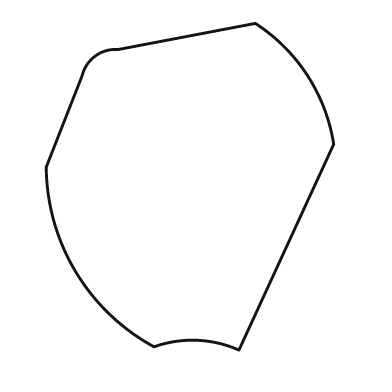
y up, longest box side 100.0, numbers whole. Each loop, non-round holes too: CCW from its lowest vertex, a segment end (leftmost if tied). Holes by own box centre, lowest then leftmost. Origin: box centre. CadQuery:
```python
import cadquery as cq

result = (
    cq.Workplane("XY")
    .moveTo(15.0, -50.0)
    .lineTo(44.0, 13.0)
    .threePointArc((36.0, 34.0), (20.0, 50.0))
    .lineTo(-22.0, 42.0)
    .threePointArc((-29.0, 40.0), (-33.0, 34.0))
    .lineTo(-44.0, 6.0)
    .threePointArc((-35.0, -26.0), (-11.0, -49.0))
    .threePointArc((2.0, -47.0), (15.0, -50.0))
    .close()
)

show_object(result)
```